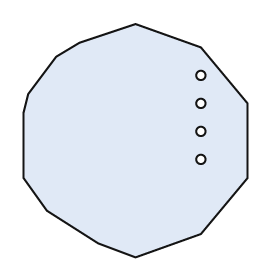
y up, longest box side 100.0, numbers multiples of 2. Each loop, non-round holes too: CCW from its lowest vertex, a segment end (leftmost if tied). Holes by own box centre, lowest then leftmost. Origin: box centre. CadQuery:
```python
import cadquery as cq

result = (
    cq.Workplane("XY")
    .moveTo(0.0, -50.0)
    .lineTo(28.0, -40.0)
    .lineTo(48.0, -16.0)
    .lineTo(48.0, 16.0)
    .lineTo(28.0, 40.0)
    .lineTo(0.0, 50.0)
    .lineTo(-24.0, 42.0)
    .lineTo(-34.0, 36.0)
    .lineTo(-46.0, 20.0)
    .lineTo(-48.0, 12.0)
    .lineTo(-48.0, -16.0)
    .lineTo(-38.0, -30.0)
    .lineTo(-16.0, -44.0)
    .close()
    .moveTo(28.0, -8.0)
    .circle(2.0)
    .moveTo(28.0, 4.0)
    .circle(2.0)
    .moveTo(28.0, 16.0)
    .circle(2.0)
    .moveTo(28.0, 28.0)
    .circle(2.0)
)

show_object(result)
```